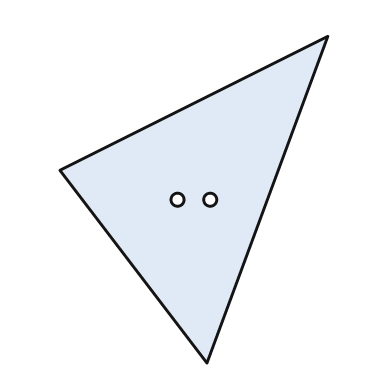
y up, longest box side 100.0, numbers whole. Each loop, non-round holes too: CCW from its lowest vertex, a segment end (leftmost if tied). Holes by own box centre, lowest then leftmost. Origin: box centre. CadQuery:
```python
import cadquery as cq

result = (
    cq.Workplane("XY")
    .moveTo(4.0, -50.0)
    .lineTo(41.0, 50.0)
    .lineTo(-41.0, 9.0)
    .close()
    .moveTo(-5.0, 0.0)
    .circle(2.0)
    .moveTo(5.0, 0.0)
    .circle(2.0)
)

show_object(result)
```